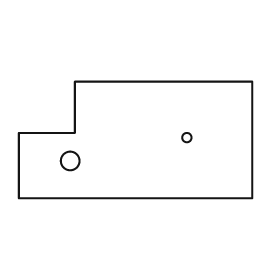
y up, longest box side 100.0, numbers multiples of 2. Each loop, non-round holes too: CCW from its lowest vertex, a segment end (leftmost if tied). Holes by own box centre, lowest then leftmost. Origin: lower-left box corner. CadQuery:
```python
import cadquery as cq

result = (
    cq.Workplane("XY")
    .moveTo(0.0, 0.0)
    .lineTo(100.0, 0.0)
    .lineTo(100.0, 50.0)
    .lineTo(24.0, 50.0)
    .lineTo(24.0, 28.0)
    .lineTo(0.0, 28.0)
    .close()
    .moveTo(22.0, 16.0)
    .circle(4.0)
    .moveTo(72.0, 26.0)
    .circle(2.0)
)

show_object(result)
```